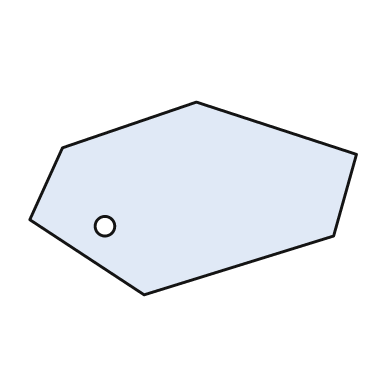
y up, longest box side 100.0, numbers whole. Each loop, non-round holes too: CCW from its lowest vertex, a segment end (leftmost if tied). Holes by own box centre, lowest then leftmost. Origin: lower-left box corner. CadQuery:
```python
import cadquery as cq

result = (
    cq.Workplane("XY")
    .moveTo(35.0, 0.0)
    .lineTo(93.0, 18.0)
    .lineTo(100.0, 43.0)
    .lineTo(51.0, 59.0)
    .lineTo(10.0, 45.0)
    .lineTo(0.0, 23.0)
    .close()
    .moveTo(23.0, 21.0)
    .circle(3.0)
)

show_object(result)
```